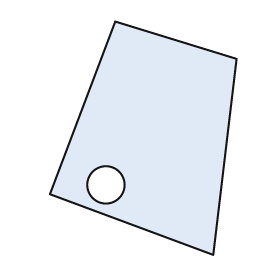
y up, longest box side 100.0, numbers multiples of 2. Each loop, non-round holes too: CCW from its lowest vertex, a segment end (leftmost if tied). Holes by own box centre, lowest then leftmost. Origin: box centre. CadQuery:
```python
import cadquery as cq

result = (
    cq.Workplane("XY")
    .moveTo(30.0, -50.0)
    .lineTo(40.0, 34.0)
    .lineTo(-12.0, 50.0)
    .lineTo(-40.0, -24.0)
    .close()
    .moveTo(-16.0, -20.0)
    .circle(8.0)
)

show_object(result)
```